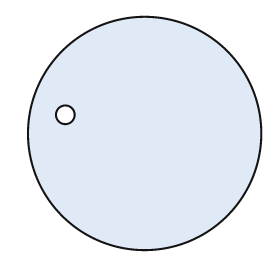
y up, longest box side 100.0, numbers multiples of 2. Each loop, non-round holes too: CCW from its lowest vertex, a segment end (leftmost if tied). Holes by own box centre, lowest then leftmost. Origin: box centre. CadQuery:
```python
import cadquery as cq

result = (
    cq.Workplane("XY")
    .moveTo(0.0, 0.0)
    .circle(50.0)
    .moveTo(-34.0, 8.0)
    .circle(4.0)
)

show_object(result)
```